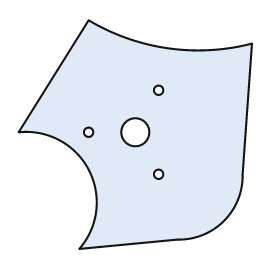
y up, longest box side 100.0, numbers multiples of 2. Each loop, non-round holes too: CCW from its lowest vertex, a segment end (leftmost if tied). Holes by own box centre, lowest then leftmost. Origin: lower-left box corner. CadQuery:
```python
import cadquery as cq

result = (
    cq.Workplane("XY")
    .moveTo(26.0, 0.0)
    .lineTo(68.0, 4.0)
    .threePointArc((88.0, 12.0), (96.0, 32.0))
    .lineTo(100.0, 88.0)
    .threePointArc((64.0, 86.0), (30.0, 98.0))
    .lineTo(0.0, 50.0)
    .threePointArc((30.0, 34.0), (26.0, 0.0))
    .close()
    .moveTo(60.0, 32.0)
    .circle(2.0)
    .moveTo(30.0, 50.0)
    .circle(2.0)
    .moveTo(50.0, 50.0)
    .circle(6.0)
    .moveTo(60.0, 68.0)
    .circle(2.0)
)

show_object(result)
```